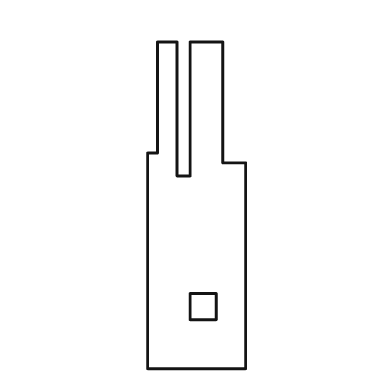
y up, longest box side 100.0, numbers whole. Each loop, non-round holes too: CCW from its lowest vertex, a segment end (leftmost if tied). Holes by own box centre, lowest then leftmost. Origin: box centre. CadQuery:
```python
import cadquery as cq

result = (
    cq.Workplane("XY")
    .moveTo(-15.0, -50.0)
    .lineTo(15.0, -50.0)
    .lineTo(15.0, 13.0)
    .lineTo(8.0, 13.0)
    .lineTo(8.0, 50.0)
    .lineTo(-2.0, 50.0)
    .lineTo(-2.0, 9.0)
    .lineTo(-6.0, 9.0)
    .lineTo(-6.0, 50.0)
    .lineTo(-12.0, 50.0)
    .lineTo(-12.0, 16.0)
    .lineTo(-15.0, 16.0)
    .close()
    .moveTo(-2.0, -35.0)
    .lineTo(6.0, -35.0)
    .lineTo(6.0, -27.0)
    .lineTo(-2.0, -27.0)
    .close()
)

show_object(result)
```